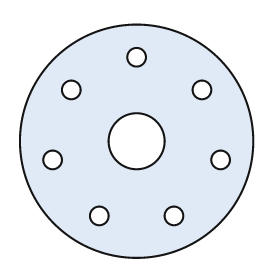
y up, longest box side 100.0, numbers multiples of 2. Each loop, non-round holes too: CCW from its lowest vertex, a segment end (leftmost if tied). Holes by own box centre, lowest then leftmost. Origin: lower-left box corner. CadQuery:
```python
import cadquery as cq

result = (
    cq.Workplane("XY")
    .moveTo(50.0, 50.0)
    .circle(50.0)
    .moveTo(34.0, 18.0)
    .circle(4.0)
    .moveTo(66.0, 18.0)
    .circle(4.0)
    .moveTo(14.0, 42.0)
    .circle(4.0)
    .moveTo(86.0, 42.0)
    .circle(4.0)
    .moveTo(50.0, 50.0)
    .circle(12.0)
    .moveTo(22.0, 72.0)
    .circle(4.0)
    .moveTo(78.0, 72.0)
    .circle(4.0)
    .moveTo(50.0, 86.0)
    .circle(4.0)
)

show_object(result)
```